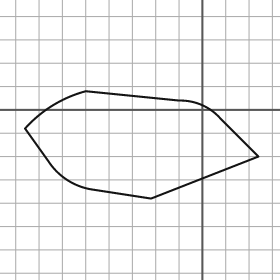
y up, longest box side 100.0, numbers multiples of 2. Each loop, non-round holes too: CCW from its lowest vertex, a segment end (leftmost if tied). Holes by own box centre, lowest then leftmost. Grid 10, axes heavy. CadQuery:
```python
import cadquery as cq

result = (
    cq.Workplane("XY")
    .moveTo(-22.0, -38.0)
    .lineTo(24.0, -20.0)
    .lineTo(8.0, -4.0)
    .threePointArc((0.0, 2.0), (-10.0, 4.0))
    .lineTo(-50.0, 8.0)
    .threePointArc((-64.0, 2.0), (-76.0, -8.0))
    .lineTo(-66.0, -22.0)
    .threePointArc((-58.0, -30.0), (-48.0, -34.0))
    .close()
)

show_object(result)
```